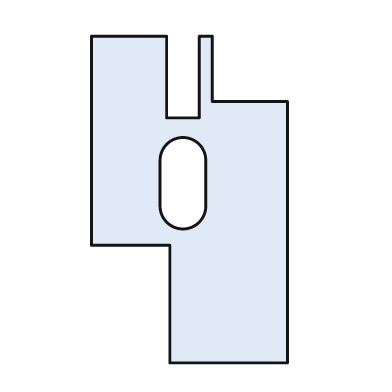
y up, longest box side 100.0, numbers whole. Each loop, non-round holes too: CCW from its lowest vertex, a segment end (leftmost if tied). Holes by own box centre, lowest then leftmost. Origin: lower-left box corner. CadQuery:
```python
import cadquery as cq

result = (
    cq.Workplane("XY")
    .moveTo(24.0, 0.0)
    .lineTo(60.0, 0.0)
    .lineTo(60.0, 80.0)
    .lineTo(37.0, 80.0)
    .lineTo(37.0, 100.0)
    .lineTo(33.0, 100.0)
    .lineTo(33.0, 75.0)
    .lineTo(23.0, 75.0)
    .lineTo(23.0, 100.0)
    .lineTo(0.0, 100.0)
    .lineTo(0.0, 36.0)
    .lineTo(24.0, 36.0)
    .close()
    .moveTo(21.0, 48.0)
    .threePointArc((28.0, 41.0), (35.0, 48.0))
    .lineTo(35.0, 62.0)
    .threePointArc((28.0, 69.0), (21.0, 62.0))
    .close()
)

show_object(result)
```